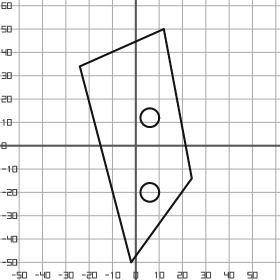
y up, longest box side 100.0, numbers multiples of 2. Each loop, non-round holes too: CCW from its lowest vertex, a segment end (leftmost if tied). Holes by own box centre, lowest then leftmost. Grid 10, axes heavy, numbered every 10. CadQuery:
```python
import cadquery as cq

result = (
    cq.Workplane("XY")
    .moveTo(-2.0, -50.0)
    .lineTo(24.0, -14.0)
    .lineTo(12.0, 50.0)
    .lineTo(-24.0, 34.0)
    .close()
    .moveTo(6.0, -20.0)
    .circle(4.0)
    .moveTo(6.0, 12.0)
    .circle(4.0)
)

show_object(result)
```